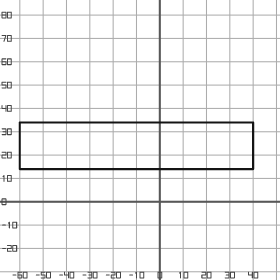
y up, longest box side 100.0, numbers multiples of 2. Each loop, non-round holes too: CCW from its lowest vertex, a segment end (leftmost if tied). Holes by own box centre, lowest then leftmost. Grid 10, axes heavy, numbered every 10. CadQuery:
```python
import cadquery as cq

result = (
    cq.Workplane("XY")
    .moveTo(-60.0, 14.0)
    .lineTo(40.0, 14.0)
    .lineTo(40.0, 34.0)
    .lineTo(-60.0, 34.0)
    .close()
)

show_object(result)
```